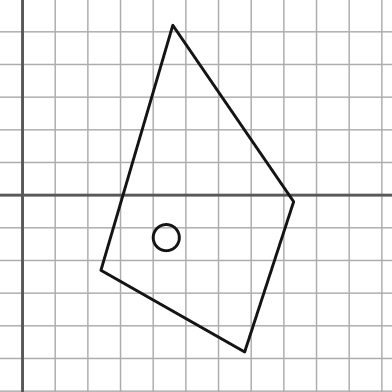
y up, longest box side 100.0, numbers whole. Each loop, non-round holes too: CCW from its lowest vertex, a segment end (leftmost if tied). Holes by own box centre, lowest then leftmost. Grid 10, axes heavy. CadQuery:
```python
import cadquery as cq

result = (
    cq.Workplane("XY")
    .moveTo(68.0, -48.0)
    .lineTo(83.0, -2.0)
    .lineTo(46.0, 52.0)
    .lineTo(24.0, -23.0)
    .close()
    .moveTo(44.0, -13.0)
    .circle(4.0)
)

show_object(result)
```